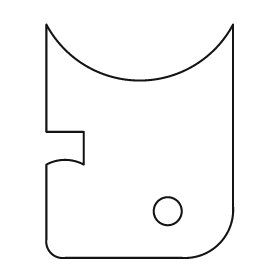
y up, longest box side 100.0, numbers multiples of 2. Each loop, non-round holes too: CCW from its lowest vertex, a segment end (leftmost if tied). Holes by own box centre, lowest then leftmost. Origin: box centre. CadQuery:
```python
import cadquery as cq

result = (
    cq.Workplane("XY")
    .moveTo(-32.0, -50.0)
    .lineTo(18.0, -50.0)
    .threePointArc((34.0, -44.0), (40.0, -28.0))
    .lineTo(40.0, 50.0)
    .threePointArc((0.0, 26.0), (-40.0, 50.0))
    .lineTo(-40.0, 4.0)
    .lineTo(-24.0, 4.0)
    .lineTo(-24.0, -10.0)
    .threePointArc((-32.0, -8.0), (-40.0, -10.0))
    .lineTo(-40.0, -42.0)
    .threePointArc((-38.0, -48.0), (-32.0, -50.0))
    .close()
    .moveTo(12.0, -30.0)
    .circle(6.0)
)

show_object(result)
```